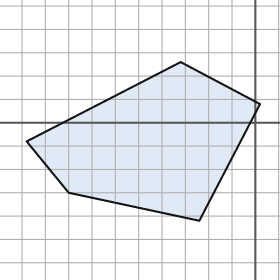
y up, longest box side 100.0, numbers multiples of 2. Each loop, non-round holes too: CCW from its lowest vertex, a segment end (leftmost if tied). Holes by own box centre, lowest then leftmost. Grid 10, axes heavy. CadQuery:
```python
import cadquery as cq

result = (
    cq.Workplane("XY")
    .moveTo(-24.0, -42.0)
    .lineTo(2.0, 8.0)
    .lineTo(-32.0, 26.0)
    .lineTo(-98.0, -8.0)
    .lineTo(-80.0, -30.0)
    .close()
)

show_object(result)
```